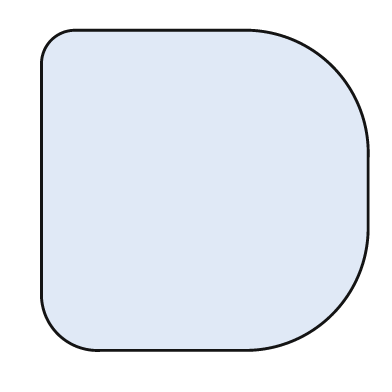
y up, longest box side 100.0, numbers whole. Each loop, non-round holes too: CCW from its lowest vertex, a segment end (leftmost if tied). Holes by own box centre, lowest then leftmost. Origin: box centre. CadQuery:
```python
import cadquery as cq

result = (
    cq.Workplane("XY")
    .moveTo(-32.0, -49.0)
    .lineTo(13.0, -49.0)
    .threePointArc((39.0, -38.0), (50.0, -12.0))
    .lineTo(50.0, 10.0)
    .threePointArc((39.0, 38.0), (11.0, 49.0))
    .lineTo(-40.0, 49.0)
    .threePointArc((-47.0, 46.0), (-50.0, 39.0))
    .lineTo(-50.0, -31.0)
    .threePointArc((-45.0, -44.0), (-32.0, -49.0))
    .close()
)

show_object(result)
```